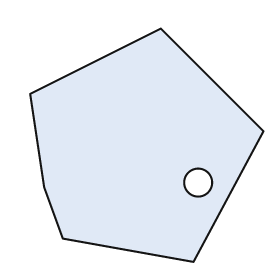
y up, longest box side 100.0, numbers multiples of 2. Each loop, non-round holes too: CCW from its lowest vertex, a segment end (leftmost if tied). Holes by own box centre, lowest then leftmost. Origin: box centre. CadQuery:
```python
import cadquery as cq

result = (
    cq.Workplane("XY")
    .moveTo(20.0, -50.0)
    .lineTo(50.0, 6.0)
    .lineTo(6.0, 50.0)
    .lineTo(-50.0, 22.0)
    .lineTo(-44.0, -18.0)
    .lineTo(-36.0, -40.0)
    .close()
    .moveTo(22.0, -16.0)
    .circle(6.0)
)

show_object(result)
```